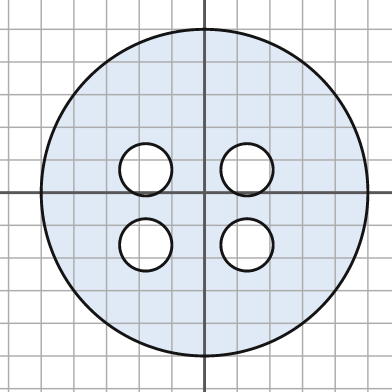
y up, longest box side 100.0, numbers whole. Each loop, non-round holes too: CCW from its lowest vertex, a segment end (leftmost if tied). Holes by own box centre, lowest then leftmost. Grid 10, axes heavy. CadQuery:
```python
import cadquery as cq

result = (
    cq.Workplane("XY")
    .moveTo(0.0, 0.0)
    .circle(50.0)
    .moveTo(-18.0, -16.0)
    .circle(8.0)
    .moveTo(13.0, -16.0)
    .circle(8.0)
    .moveTo(-18.0, 7.0)
    .circle(8.0)
    .moveTo(13.0, 7.0)
    .circle(8.0)
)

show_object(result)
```